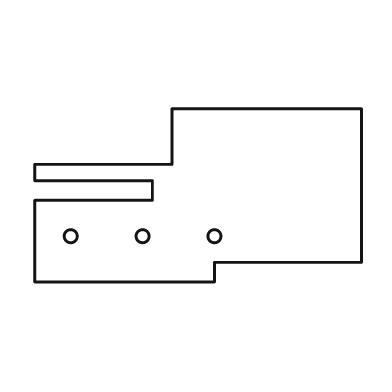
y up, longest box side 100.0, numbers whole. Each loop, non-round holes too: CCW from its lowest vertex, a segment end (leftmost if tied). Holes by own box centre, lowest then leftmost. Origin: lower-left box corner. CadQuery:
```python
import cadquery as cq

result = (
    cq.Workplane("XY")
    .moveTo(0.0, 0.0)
    .lineTo(55.0, 0.0)
    .lineTo(55.0, 6.0)
    .lineTo(100.0, 6.0)
    .lineTo(100.0, 53.0)
    .lineTo(42.0, 53.0)
    .lineTo(42.0, 36.0)
    .lineTo(0.0, 36.0)
    .lineTo(0.0, 31.0)
    .lineTo(36.0, 31.0)
    .lineTo(36.0, 25.0)
    .lineTo(0.0, 25.0)
    .close()
    .moveTo(11.0, 14.0)
    .circle(2.0)
    .moveTo(33.0, 14.0)
    .circle(2.0)
    .moveTo(55.0, 14.0)
    .circle(2.0)
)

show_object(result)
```